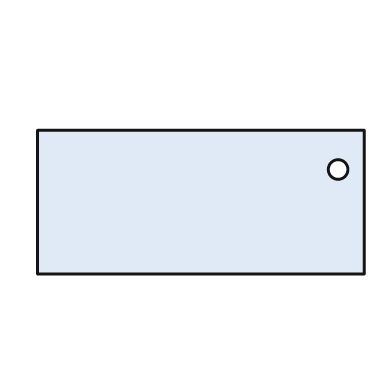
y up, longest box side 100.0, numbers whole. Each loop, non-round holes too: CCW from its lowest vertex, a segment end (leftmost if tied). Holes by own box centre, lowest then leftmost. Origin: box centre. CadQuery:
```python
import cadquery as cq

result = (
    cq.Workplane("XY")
    .moveTo(-50.0, -22.0)
    .lineTo(50.0, -22.0)
    .lineTo(50.0, 22.0)
    .lineTo(-50.0, 22.0)
    .close()
    .moveTo(42.0, 10.0)
    .circle(3.0)
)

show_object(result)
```